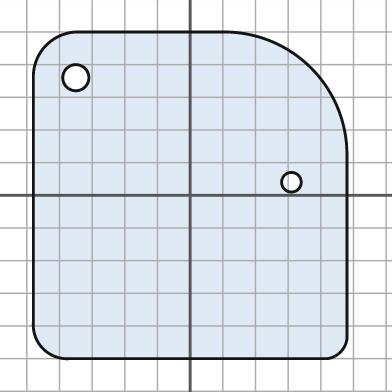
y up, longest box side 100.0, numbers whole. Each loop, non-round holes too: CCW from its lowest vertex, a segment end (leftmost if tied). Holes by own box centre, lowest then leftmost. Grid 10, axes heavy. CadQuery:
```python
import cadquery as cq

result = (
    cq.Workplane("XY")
    .moveTo(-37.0, -50.0)
    .lineTo(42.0, -50.0)
    .threePointArc((46.0, -48.0), (48.0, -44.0))
    .lineTo(48.0, 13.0)
    .threePointArc((37.0, 39.0), (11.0, 50.0))
    .lineTo(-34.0, 50.0)
    .threePointArc((-44.0, 46.0), (-48.0, 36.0))
    .lineTo(-48.0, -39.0)
    .threePointArc((-45.0, -47.0), (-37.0, -50.0))
    .close()
    .moveTo(31.0, 4.0)
    .circle(3.0)
    .moveTo(-35.0, 36.0)
    .circle(4.0)
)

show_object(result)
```